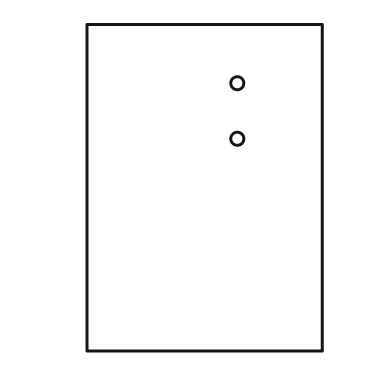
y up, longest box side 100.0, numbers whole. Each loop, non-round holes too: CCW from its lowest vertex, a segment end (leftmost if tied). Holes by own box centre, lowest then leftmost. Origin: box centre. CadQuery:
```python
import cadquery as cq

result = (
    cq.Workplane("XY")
    .moveTo(-36.0, -50.0)
    .lineTo(36.0, -50.0)
    .lineTo(36.0, 50.0)
    .lineTo(-36.0, 50.0)
    .close()
    .moveTo(10.0, 15.0)
    .circle(2.0)
    .moveTo(10.0, 32.0)
    .circle(2.0)
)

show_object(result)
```